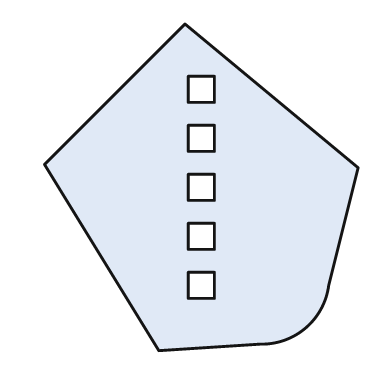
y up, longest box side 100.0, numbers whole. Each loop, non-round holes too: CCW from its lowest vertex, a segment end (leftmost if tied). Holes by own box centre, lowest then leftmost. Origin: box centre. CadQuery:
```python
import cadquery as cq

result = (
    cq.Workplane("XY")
    .moveTo(-13.0, -50.0)
    .lineTo(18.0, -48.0)
    .threePointArc((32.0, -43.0), (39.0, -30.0))
    .lineTo(48.0, 6.0)
    .lineTo(-5.0, 50.0)
    .lineTo(-48.0, 7.0)
    .close()
    .moveTo(-4.0, -34.0)
    .lineTo(4.0, -34.0)
    .lineTo(4.0, -26.0)
    .lineTo(-4.0, -26.0)
    .close()
    .moveTo(-4.0, -19.0)
    .lineTo(4.0, -19.0)
    .lineTo(4.0, -11.0)
    .lineTo(-4.0, -11.0)
    .close()
    .moveTo(-4.0, -4.0)
    .lineTo(4.0, -4.0)
    .lineTo(4.0, 4.0)
    .lineTo(-4.0, 4.0)
    .close()
    .moveTo(-4.0, 11.0)
    .lineTo(4.0, 11.0)
    .lineTo(4.0, 19.0)
    .lineTo(-4.0, 19.0)
    .close()
    .moveTo(-4.0, 26.0)
    .lineTo(4.0, 26.0)
    .lineTo(4.0, 34.0)
    .lineTo(-4.0, 34.0)
    .close()
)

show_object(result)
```